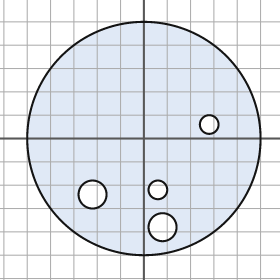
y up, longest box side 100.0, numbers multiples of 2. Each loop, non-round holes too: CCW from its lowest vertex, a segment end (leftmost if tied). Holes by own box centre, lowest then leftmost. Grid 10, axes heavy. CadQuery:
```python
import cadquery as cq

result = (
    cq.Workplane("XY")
    .moveTo(0.0, 0.0)
    .circle(50.0)
    .moveTo(8.0, -38.0)
    .circle(6.0)
    .moveTo(-22.0, -24.0)
    .circle(6.0)
    .moveTo(6.0, -22.0)
    .circle(4.0)
    .moveTo(28.0, 6.0)
    .circle(4.0)
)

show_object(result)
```